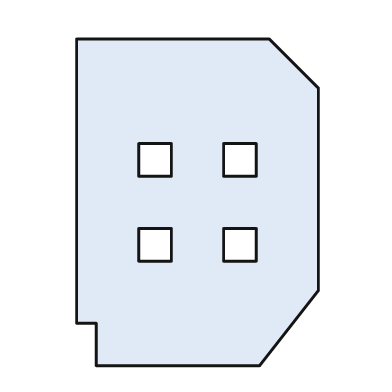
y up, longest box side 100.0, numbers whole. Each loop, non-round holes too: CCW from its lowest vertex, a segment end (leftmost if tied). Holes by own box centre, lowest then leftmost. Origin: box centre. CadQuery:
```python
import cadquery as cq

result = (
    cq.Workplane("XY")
    .moveTo(-31.0, -50.0)
    .lineTo(19.0, -50.0)
    .lineTo(37.0, -27.0)
    .lineTo(37.0, 35.0)
    .lineTo(22.0, 50.0)
    .lineTo(-37.0, 50.0)
    .lineTo(-37.0, -37.0)
    .lineTo(-31.0, -37.0)
    .close()
    .moveTo(-18.0, -18.0)
    .lineTo(-8.0, -18.0)
    .lineTo(-8.0, -8.0)
    .lineTo(-18.0, -8.0)
    .close()
    .moveTo(8.0, -18.0)
    .lineTo(18.0, -18.0)
    .lineTo(18.0, -8.0)
    .lineTo(8.0, -8.0)
    .close()
    .moveTo(-18.0, 8.0)
    .lineTo(-8.0, 8.0)
    .lineTo(-8.0, 18.0)
    .lineTo(-18.0, 18.0)
    .close()
    .moveTo(8.0, 8.0)
    .lineTo(18.0, 8.0)
    .lineTo(18.0, 18.0)
    .lineTo(8.0, 18.0)
    .close()
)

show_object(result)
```